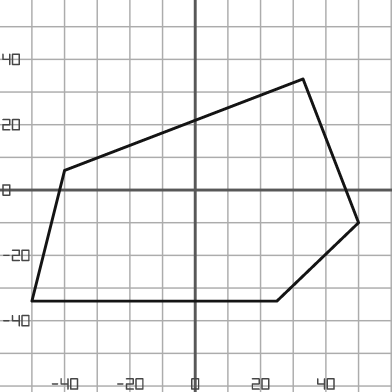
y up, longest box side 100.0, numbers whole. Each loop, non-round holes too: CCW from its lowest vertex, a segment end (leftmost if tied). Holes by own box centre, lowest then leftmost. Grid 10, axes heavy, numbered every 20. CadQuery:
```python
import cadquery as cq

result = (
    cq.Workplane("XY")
    .moveTo(-50.0, -34.0)
    .lineTo(25.0, -34.0)
    .lineTo(50.0, -10.0)
    .lineTo(33.0, 34.0)
    .lineTo(-40.0, 6.0)
    .close()
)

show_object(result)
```